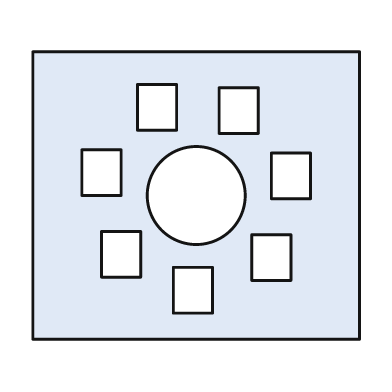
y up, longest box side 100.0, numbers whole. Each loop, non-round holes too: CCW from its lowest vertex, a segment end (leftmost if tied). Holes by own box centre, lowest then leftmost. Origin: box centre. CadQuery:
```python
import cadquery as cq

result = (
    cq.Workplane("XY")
    .moveTo(-50.0, -44.0)
    .lineTo(50.0, -44.0)
    .lineTo(50.0, 44.0)
    .lineTo(-50.0, 44.0)
    .close()
    .moveTo(-7.0, -36.0)
    .lineTo(5.0, -36.0)
    .lineTo(5.0, -22.0)
    .lineTo(-7.0, -22.0)
    .close()
    .moveTo(17.0, -26.0)
    .lineTo(29.0, -26.0)
    .lineTo(29.0, -12.0)
    .lineTo(17.0, -12.0)
    .close()
    .moveTo(-29.0, -25.0)
    .lineTo(-17.0, -25.0)
    .lineTo(-17.0, -11.0)
    .lineTo(-29.0, -11.0)
    .close()
    .moveTo(0.0, 0.0)
    .circle(15.0)
    .moveTo(23.0, -1.0)
    .lineTo(35.0, -1.0)
    .lineTo(35.0, 13.0)
    .lineTo(23.0, 13.0)
    .close()
    .moveTo(-35.0, 0.0)
    .lineTo(-23.0, 0.0)
    .lineTo(-23.0, 14.0)
    .lineTo(-35.0, 14.0)
    .close()
    .moveTo(7.0, 19.0)
    .lineTo(19.0, 19.0)
    .lineTo(19.0, 33.0)
    .lineTo(7.0, 33.0)
    .close()
    .moveTo(-18.0, 20.0)
    .lineTo(-6.0, 20.0)
    .lineTo(-6.0, 34.0)
    .lineTo(-18.0, 34.0)
    .close()
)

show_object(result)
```